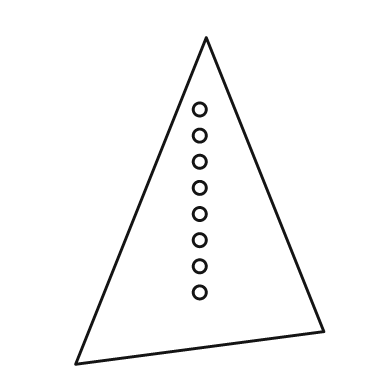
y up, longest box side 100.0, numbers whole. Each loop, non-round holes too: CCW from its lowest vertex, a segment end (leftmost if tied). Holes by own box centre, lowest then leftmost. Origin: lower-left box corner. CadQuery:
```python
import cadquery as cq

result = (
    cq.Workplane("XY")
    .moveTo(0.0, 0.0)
    .lineTo(76.0, 10.0)
    .lineTo(40.0, 100.0)
    .close()
    .moveTo(38.0, 22.0)
    .circle(2.0)
    .moveTo(38.0, 30.0)
    .circle(2.0)
    .moveTo(38.0, 38.0)
    .circle(2.0)
    .moveTo(38.0, 46.0)
    .circle(2.0)
    .moveTo(38.0, 54.0)
    .circle(2.0)
    .moveTo(38.0, 62.0)
    .circle(2.0)
    .moveTo(38.0, 70.0)
    .circle(2.0)
    .moveTo(38.0, 78.0)
    .circle(2.0)
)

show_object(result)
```